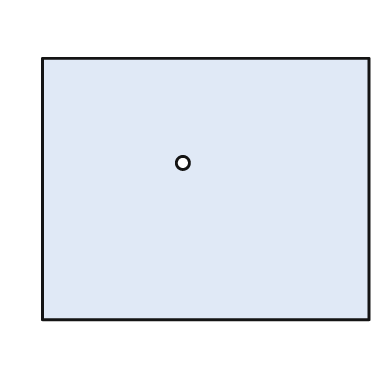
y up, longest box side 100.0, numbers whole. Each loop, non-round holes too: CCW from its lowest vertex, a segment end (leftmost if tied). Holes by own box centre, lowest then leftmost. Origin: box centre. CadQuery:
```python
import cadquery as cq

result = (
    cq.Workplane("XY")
    .moveTo(-50.0, -40.0)
    .lineTo(50.0, -40.0)
    .lineTo(50.0, 40.0)
    .lineTo(-50.0, 40.0)
    .close()
    .moveTo(-7.0, 8.0)
    .circle(2.0)
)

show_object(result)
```